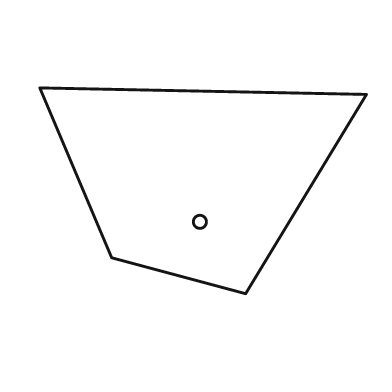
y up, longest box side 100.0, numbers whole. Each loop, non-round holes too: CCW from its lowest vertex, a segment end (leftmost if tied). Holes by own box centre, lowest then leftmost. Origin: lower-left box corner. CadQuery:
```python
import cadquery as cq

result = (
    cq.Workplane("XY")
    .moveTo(63.0, 0.0)
    .lineTo(100.0, 61.0)
    .lineTo(0.0, 63.0)
    .lineTo(22.0, 11.0)
    .close()
    .moveTo(49.0, 22.0)
    .circle(2.0)
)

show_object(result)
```